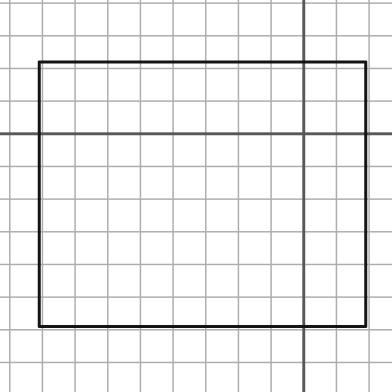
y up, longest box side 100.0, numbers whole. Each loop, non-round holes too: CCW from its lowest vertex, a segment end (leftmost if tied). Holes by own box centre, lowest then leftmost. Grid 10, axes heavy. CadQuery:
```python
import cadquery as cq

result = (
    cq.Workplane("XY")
    .moveTo(-81.0, -59.0)
    .lineTo(19.0, -59.0)
    .lineTo(19.0, 22.0)
    .lineTo(-81.0, 22.0)
    .close()
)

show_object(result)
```